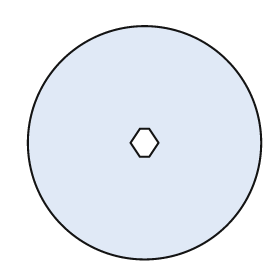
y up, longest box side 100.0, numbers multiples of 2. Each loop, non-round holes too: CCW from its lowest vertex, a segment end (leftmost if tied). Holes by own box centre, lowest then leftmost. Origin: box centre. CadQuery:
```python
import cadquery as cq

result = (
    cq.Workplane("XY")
    .moveTo(0.0, 0.0)
    .circle(50.0)
    .moveTo(-2.0, -6.0)
    .lineTo(2.0, -6.0)
    .lineTo(6.0, 0.0)
    .lineTo(2.0, 6.0)
    .lineTo(-2.0, 6.0)
    .lineTo(-6.0, 0.0)
    .close()
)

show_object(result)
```